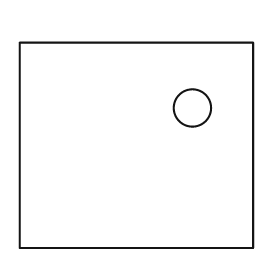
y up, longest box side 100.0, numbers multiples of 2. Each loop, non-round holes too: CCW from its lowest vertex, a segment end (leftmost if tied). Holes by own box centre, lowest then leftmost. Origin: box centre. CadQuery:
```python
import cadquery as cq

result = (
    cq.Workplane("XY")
    .moveTo(-50.0, -44.0)
    .lineTo(50.0, -44.0)
    .lineTo(50.0, 44.0)
    .lineTo(-50.0, 44.0)
    .close()
    .moveTo(24.0, 16.0)
    .circle(8.0)
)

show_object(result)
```